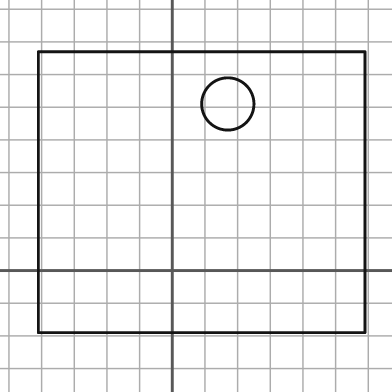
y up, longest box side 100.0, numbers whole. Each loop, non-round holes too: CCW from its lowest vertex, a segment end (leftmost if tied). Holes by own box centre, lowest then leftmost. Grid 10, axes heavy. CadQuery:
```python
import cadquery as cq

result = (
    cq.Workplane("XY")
    .moveTo(-41.0, -19.0)
    .lineTo(59.0, -19.0)
    .lineTo(59.0, 67.0)
    .lineTo(-41.0, 67.0)
    .close()
    .moveTo(17.0, 51.0)
    .circle(8.0)
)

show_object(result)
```